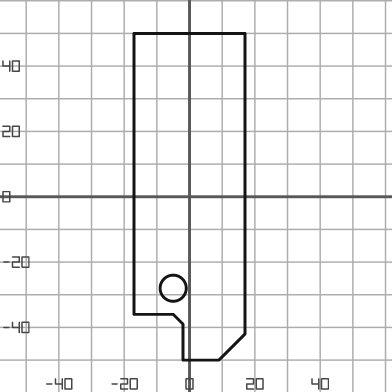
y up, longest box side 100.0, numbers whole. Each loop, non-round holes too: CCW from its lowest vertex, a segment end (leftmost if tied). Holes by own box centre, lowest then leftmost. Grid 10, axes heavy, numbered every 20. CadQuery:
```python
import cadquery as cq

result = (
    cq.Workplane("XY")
    .moveTo(-2.0, -50.0)
    .lineTo(9.0, -50.0)
    .lineTo(17.0, -42.0)
    .lineTo(17.0, 50.0)
    .lineTo(-17.0, 50.0)
    .lineTo(-17.0, -36.0)
    .lineTo(-5.0, -36.0)
    .lineTo(-2.0, -39.0)
    .close()
    .moveTo(-5.0, -28.0)
    .circle(4.0)
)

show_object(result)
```